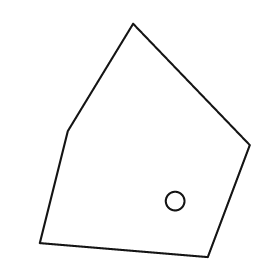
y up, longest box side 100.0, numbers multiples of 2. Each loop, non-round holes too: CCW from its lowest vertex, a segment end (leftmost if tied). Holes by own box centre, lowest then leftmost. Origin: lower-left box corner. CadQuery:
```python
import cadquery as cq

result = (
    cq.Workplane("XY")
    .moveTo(72.0, 0.0)
    .lineTo(90.0, 48.0)
    .lineTo(40.0, 100.0)
    .lineTo(12.0, 54.0)
    .lineTo(0.0, 6.0)
    .close()
    .moveTo(58.0, 24.0)
    .circle(4.0)
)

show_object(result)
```